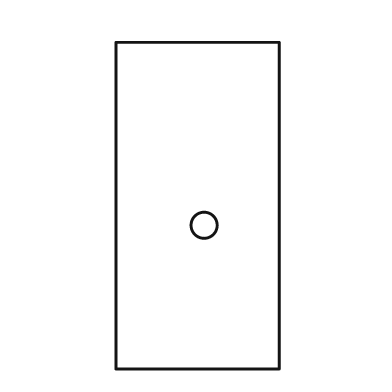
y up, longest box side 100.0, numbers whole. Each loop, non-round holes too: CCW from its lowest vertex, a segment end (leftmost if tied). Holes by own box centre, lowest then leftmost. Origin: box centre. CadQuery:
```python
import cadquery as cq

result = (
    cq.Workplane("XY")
    .moveTo(-25.0, -50.0)
    .lineTo(25.0, -50.0)
    .lineTo(25.0, 50.0)
    .lineTo(-25.0, 50.0)
    .close()
    .moveTo(2.0, -6.0)
    .circle(4.0)
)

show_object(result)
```